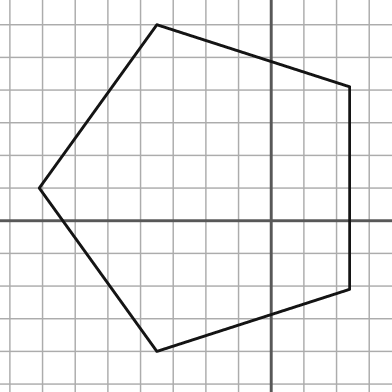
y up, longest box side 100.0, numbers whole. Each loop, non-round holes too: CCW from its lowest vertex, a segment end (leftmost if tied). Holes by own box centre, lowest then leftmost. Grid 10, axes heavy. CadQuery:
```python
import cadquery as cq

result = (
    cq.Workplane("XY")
    .moveTo(-35.0, -40.0)
    .lineTo(24.0, -21.0)
    .lineTo(24.0, 41.0)
    .lineTo(-35.0, 60.0)
    .lineTo(-71.0, 10.0)
    .close()
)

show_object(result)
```